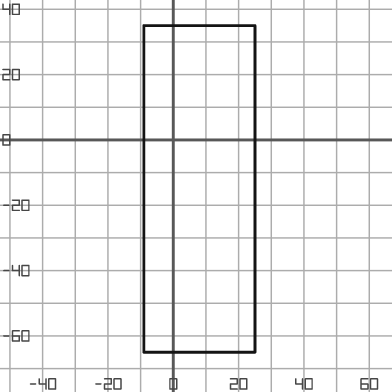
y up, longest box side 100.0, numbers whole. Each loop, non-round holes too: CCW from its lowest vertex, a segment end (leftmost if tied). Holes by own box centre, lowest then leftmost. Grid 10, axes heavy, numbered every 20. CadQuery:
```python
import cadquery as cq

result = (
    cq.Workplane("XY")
    .moveTo(-9.0, -65.0)
    .lineTo(25.0, -65.0)
    .lineTo(25.0, 35.0)
    .lineTo(-9.0, 35.0)
    .close()
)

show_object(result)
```